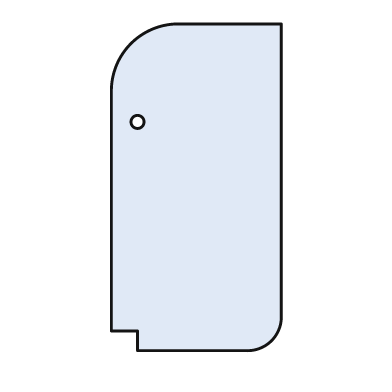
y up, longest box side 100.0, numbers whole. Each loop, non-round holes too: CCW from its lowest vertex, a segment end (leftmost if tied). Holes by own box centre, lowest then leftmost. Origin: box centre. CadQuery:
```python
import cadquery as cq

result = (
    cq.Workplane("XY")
    .moveTo(-18.0, -50.0)
    .lineTo(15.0, -50.0)
    .threePointArc((23.0, -47.0), (26.0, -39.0))
    .lineTo(26.0, 50.0)
    .lineTo(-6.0, 50.0)
    .threePointArc((-20.0, 44.0), (-26.0, 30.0))
    .lineTo(-26.0, -44.0)
    .lineTo(-18.0, -44.0)
    .close()
    .moveTo(-18.0, 20.0)
    .circle(2.0)
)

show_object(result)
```